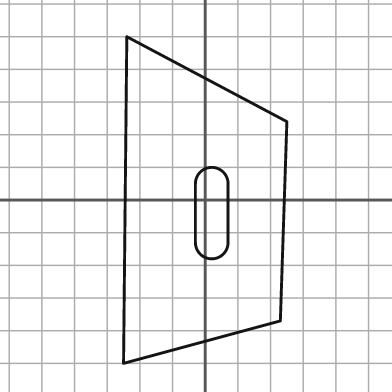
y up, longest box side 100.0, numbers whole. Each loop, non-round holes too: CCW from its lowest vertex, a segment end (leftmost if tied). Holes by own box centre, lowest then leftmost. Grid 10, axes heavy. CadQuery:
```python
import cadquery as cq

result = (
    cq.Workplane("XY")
    .moveTo(-25.0, -50.0)
    .lineTo(23.0, -37.0)
    .lineTo(25.0, 24.0)
    .lineTo(-24.0, 50.0)
    .close()
    .moveTo(-3.0, -13.0)
    .threePointArc((2.0, -18.0), (7.0, -13.0))
    .lineTo(7.0, 5.0)
    .threePointArc((2.0, 10.0), (-3.0, 5.0))
    .close()
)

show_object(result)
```